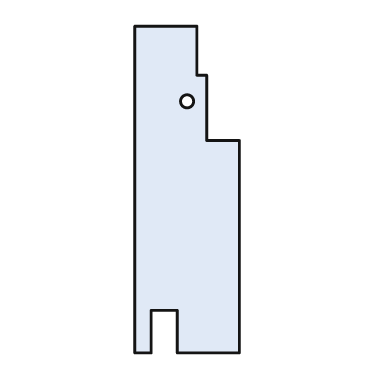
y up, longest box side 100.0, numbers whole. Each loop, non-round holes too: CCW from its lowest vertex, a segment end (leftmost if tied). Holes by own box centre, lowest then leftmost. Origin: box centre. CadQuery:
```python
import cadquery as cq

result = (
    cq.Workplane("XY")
    .moveTo(-16.0, -50.0)
    .lineTo(-11.0, -50.0)
    .lineTo(-11.0, -37.0)
    .lineTo(-3.0, -37.0)
    .lineTo(-3.0, -50.0)
    .lineTo(16.0, -50.0)
    .lineTo(16.0, 15.0)
    .lineTo(6.0, 15.0)
    .lineTo(6.0, 35.0)
    .lineTo(3.0, 35.0)
    .lineTo(3.0, 50.0)
    .lineTo(-16.0, 50.0)
    .close()
    .moveTo(0.0, 27.0)
    .circle(2.0)
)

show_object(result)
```